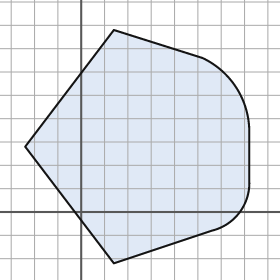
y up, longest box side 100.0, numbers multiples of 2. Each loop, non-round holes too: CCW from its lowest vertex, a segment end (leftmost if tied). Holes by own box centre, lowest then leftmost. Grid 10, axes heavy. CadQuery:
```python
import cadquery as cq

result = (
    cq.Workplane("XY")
    .moveTo(14.0, -22.0)
    .lineTo(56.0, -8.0)
    .threePointArc((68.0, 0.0), (72.0, 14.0))
    .lineTo(72.0, 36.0)
    .threePointArc((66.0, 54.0), (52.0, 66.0))
    .lineTo(14.0, 78.0)
    .lineTo(-24.0, 28.0)
    .close()
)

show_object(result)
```